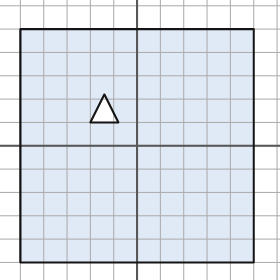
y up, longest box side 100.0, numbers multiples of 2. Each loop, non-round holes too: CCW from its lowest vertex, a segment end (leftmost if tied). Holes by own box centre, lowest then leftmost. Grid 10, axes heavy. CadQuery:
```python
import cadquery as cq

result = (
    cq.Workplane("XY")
    .moveTo(-50.0, -50.0)
    .lineTo(50.0, -50.0)
    .lineTo(50.0, 50.0)
    .lineTo(-50.0, 50.0)
    .close()
    .moveTo(-20.0, 10.0)
    .lineTo(-8.0, 10.0)
    .lineTo(-14.0, 22.0)
    .close()
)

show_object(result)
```